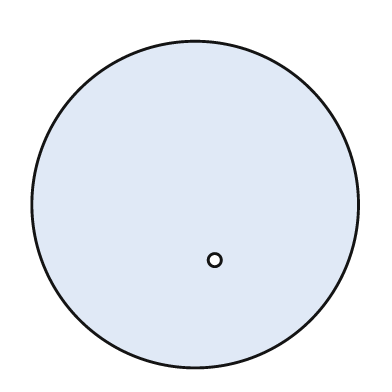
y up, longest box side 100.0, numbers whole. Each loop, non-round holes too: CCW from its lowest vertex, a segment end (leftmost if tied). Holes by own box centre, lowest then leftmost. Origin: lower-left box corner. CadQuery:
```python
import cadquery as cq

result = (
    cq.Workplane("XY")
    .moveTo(50.0, 50.0)
    .circle(50.0)
    .moveTo(56.0, 33.0)
    .circle(2.0)
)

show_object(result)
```